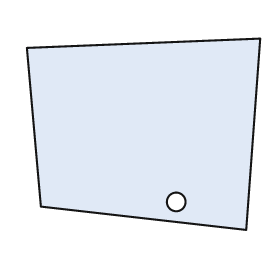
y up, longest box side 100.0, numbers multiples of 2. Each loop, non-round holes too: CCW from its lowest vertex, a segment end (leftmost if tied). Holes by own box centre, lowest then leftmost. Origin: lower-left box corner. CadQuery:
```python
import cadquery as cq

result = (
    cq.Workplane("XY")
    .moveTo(94.0, 0.0)
    .lineTo(100.0, 82.0)
    .lineTo(0.0, 78.0)
    .lineTo(6.0, 10.0)
    .close()
    .moveTo(64.0, 12.0)
    .circle(4.0)
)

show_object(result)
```